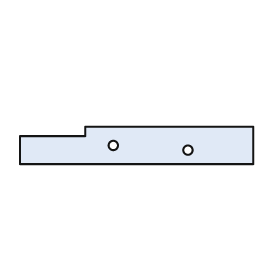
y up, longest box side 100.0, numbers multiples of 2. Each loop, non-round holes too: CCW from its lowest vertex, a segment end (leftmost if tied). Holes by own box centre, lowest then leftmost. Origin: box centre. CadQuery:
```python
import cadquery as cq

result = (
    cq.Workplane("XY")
    .moveTo(-50.0, -8.0)
    .lineTo(50.0, -8.0)
    .lineTo(50.0, 8.0)
    .lineTo(-22.0, 8.0)
    .lineTo(-22.0, 4.0)
    .lineTo(-50.0, 4.0)
    .close()
    .moveTo(22.0, -2.0)
    .circle(2.0)
    .moveTo(-10.0, 0.0)
    .circle(2.0)
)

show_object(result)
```